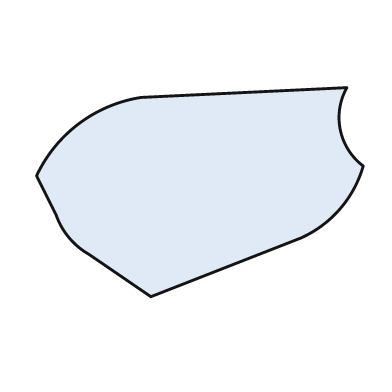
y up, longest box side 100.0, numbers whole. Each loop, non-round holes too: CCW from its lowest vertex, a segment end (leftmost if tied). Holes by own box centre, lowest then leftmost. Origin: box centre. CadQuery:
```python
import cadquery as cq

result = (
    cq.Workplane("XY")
    .moveTo(-15.0, -32.0)
    .lineTo(31.0, -14.0)
    .threePointArc((43.0, -5.0), (50.0, 8.0))
    .threePointArc((43.0, 19.0), (45.0, 32.0))
    .lineTo(-18.0, 29.0)
    .threePointArc((-37.0, 21.0), (-50.0, 5.0))
    .lineTo(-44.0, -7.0)
    .threePointArc((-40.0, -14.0), (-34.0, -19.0))
    .close()
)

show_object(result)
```